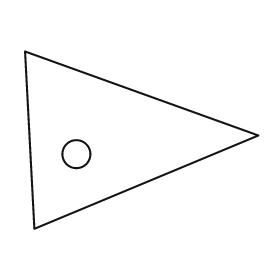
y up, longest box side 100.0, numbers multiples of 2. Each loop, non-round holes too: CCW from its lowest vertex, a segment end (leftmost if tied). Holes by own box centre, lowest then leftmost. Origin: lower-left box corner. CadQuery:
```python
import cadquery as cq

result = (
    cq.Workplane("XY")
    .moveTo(4.0, 0.0)
    .lineTo(100.0, 40.0)
    .lineTo(0.0, 76.0)
    .close()
    .moveTo(22.0, 32.0)
    .circle(6.0)
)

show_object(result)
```